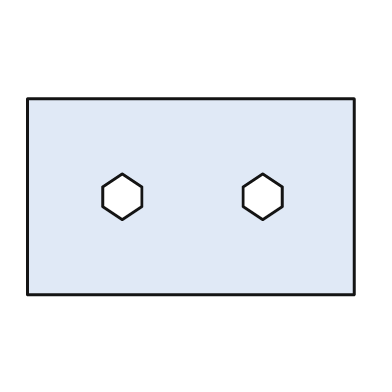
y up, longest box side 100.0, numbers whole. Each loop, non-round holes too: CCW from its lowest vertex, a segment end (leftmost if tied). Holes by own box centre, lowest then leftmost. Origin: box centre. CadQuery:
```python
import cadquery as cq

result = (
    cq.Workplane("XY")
    .moveTo(-50.0, -30.0)
    .lineTo(50.0, -30.0)
    .lineTo(50.0, 30.0)
    .lineTo(-50.0, 30.0)
    .close()
    .moveTo(-21.0, -7.0)
    .lineTo(-15.0, -3.0)
    .lineTo(-15.0, 3.0)
    .lineTo(-21.0, 7.0)
    .lineTo(-27.0, 3.0)
    .lineTo(-27.0, -3.0)
    .close()
    .moveTo(22.0, -7.0)
    .lineTo(28.0, -3.0)
    .lineTo(28.0, 3.0)
    .lineTo(22.0, 7.0)
    .lineTo(16.0, 3.0)
    .lineTo(16.0, -3.0)
    .close()
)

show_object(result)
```